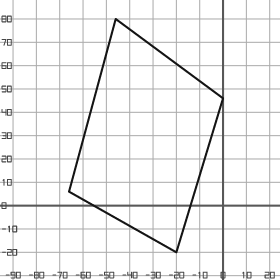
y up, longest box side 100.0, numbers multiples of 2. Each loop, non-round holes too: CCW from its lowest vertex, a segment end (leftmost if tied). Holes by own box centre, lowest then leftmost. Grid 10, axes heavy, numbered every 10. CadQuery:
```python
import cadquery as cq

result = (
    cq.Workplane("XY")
    .moveTo(-20.0, -20.0)
    .lineTo(0.0, 46.0)
    .lineTo(-46.0, 80.0)
    .lineTo(-66.0, 6.0)
    .close()
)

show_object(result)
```